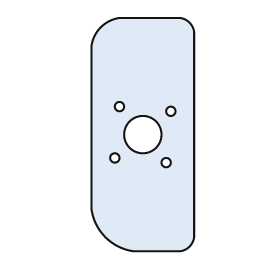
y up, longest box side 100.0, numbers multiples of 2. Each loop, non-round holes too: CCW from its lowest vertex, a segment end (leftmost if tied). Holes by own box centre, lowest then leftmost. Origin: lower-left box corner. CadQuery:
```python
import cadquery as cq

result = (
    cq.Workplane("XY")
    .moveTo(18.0, 0.0)
    .lineTo(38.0, 0.0)
    .threePointArc((42.0, 2.0), (44.0, 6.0))
    .lineTo(44.0, 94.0)
    .threePointArc((42.0, 98.0), (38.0, 100.0))
    .lineTo(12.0, 100.0)
    .threePointArc((4.0, 96.0), (0.0, 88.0))
    .lineTo(0.0, 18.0)
    .threePointArc((6.0, 6.0), (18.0, 0.0))
    .close()
    .moveTo(32.0, 38.0)
    .circle(2.0)
    .moveTo(10.0, 40.0)
    .circle(2.0)
    .moveTo(22.0, 50.0)
    .circle(8.0)
    .moveTo(34.0, 60.0)
    .circle(2.0)
    .moveTo(12.0, 62.0)
    .circle(2.0)
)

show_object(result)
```